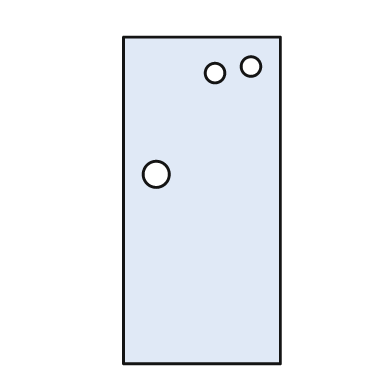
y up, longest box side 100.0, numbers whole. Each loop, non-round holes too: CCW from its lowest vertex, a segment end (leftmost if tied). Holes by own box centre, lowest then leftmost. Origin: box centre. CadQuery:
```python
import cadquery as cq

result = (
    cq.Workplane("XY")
    .moveTo(-24.0, -50.0)
    .lineTo(24.0, -50.0)
    .lineTo(24.0, 50.0)
    .lineTo(-24.0, 50.0)
    .close()
    .moveTo(-14.0, 8.0)
    .circle(4.0)
    .moveTo(4.0, 39.0)
    .circle(3.0)
    .moveTo(15.0, 41.0)
    .circle(3.0)
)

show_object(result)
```